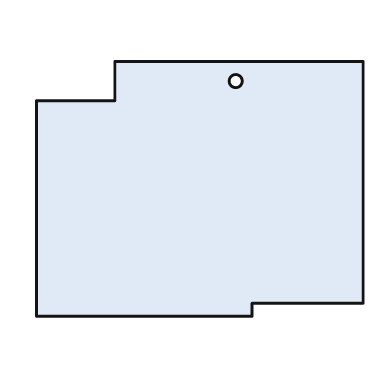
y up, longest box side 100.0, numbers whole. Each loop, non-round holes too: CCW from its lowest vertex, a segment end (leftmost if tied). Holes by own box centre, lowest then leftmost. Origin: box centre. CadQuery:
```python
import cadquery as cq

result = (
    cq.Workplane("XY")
    .moveTo(-50.0, -39.0)
    .lineTo(16.0, -39.0)
    .lineTo(16.0, -35.0)
    .lineTo(50.0, -35.0)
    .lineTo(50.0, 39.0)
    .lineTo(-26.0, 39.0)
    .lineTo(-26.0, 27.0)
    .lineTo(-50.0, 27.0)
    .close()
    .moveTo(11.0, 33.0)
    .circle(2.0)
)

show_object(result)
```